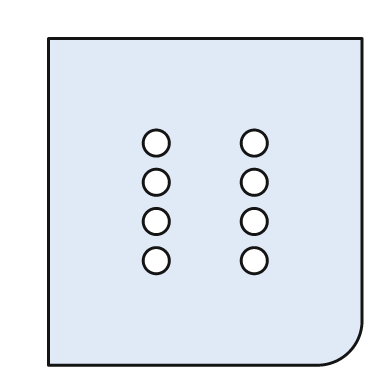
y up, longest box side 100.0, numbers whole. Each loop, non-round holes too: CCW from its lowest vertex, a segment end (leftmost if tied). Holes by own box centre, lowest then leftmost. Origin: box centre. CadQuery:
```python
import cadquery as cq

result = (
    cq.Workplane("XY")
    .moveTo(-48.0, -50.0)
    .lineTo(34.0, -50.0)
    .threePointArc((44.0, -46.0), (48.0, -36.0))
    .lineTo(48.0, 50.0)
    .lineTo(-48.0, 50.0)
    .close()
    .moveTo(-15.0, -18.0)
    .circle(4.0)
    .moveTo(15.0, -18.0)
    .circle(4.0)
    .moveTo(-15.0, -6.0)
    .circle(4.0)
    .moveTo(15.0, -6.0)
    .circle(4.0)
    .moveTo(-15.0, 6.0)
    .circle(4.0)
    .moveTo(15.0, 6.0)
    .circle(4.0)
    .moveTo(-15.0, 18.0)
    .circle(4.0)
    .moveTo(15.0, 18.0)
    .circle(4.0)
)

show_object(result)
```